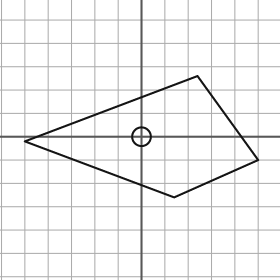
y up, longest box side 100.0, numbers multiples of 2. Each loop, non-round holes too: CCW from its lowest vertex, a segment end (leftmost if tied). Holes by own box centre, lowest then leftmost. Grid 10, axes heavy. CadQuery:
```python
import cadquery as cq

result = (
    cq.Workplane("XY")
    .moveTo(14.0, -26.0)
    .lineTo(50.0, -10.0)
    .lineTo(24.0, 26.0)
    .lineTo(-50.0, -2.0)
    .close()
    .moveTo(0.0, 0.0)
    .circle(4.0)
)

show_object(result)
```